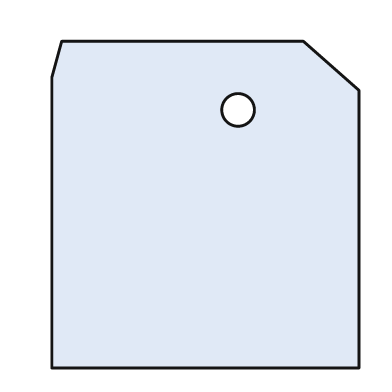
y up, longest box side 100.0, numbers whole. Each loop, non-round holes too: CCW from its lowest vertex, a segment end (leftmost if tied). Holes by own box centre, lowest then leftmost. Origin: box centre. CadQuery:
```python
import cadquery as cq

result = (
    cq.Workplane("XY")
    .moveTo(-47.0, -50.0)
    .lineTo(47.0, -50.0)
    .lineTo(47.0, 35.0)
    .lineTo(30.0, 50.0)
    .lineTo(-44.0, 50.0)
    .lineTo(-47.0, 39.0)
    .close()
    .moveTo(10.0, 29.0)
    .circle(5.0)
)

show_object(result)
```